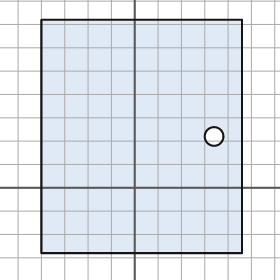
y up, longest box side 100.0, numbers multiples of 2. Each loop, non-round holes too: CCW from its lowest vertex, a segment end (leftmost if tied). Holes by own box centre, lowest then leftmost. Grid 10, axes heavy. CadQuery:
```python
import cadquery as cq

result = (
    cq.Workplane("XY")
    .moveTo(-40.0, -28.0)
    .lineTo(46.0, -28.0)
    .lineTo(46.0, 72.0)
    .lineTo(-40.0, 72.0)
    .close()
    .moveTo(34.0, 22.0)
    .circle(4.0)
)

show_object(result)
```